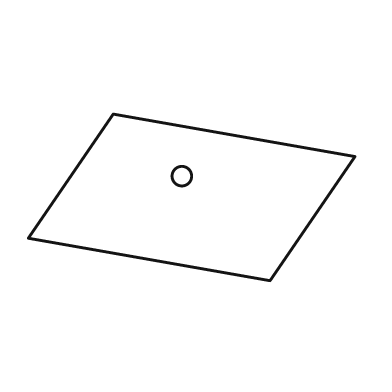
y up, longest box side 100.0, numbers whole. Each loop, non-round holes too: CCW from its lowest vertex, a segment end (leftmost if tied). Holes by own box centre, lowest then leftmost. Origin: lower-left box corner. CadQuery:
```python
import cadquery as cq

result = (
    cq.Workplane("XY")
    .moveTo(74.0, 0.0)
    .lineTo(100.0, 38.0)
    .lineTo(26.0, 51.0)
    .lineTo(0.0, 13.0)
    .close()
    .moveTo(47.0, 32.0)
    .circle(3.0)
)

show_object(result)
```